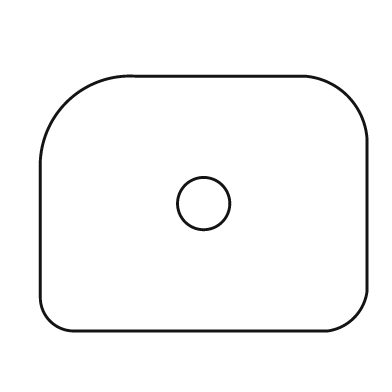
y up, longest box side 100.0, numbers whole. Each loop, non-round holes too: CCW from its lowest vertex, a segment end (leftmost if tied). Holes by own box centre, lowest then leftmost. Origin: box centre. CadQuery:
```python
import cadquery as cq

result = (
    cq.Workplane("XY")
    .moveTo(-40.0, -39.0)
    .lineTo(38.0, -39.0)
    .threePointArc((46.0, -35.0), (50.0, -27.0))
    .lineTo(50.0, 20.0)
    .threePointArc((44.0, 33.0), (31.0, 39.0))
    .lineTo(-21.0, 39.0)
    .threePointArc((-42.0, 31.0), (-50.0, 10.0))
    .lineTo(-50.0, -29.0)
    .threePointArc((-47.0, -36.0), (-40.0, -39.0))
    .close()
    .moveTo(0.0, 0.0)
    .circle(8.0)
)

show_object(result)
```